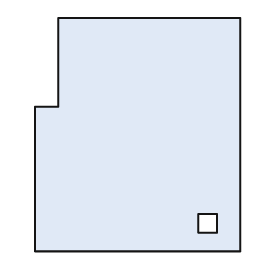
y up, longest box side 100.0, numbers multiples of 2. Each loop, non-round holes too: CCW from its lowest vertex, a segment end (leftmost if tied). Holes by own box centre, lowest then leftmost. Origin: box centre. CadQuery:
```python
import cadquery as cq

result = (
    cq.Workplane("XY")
    .moveTo(-44.0, -50.0)
    .lineTo(44.0, -50.0)
    .lineTo(44.0, 50.0)
    .lineTo(-34.0, 50.0)
    .lineTo(-34.0, 12.0)
    .lineTo(-44.0, 12.0)
    .close()
    .moveTo(26.0, -42.0)
    .lineTo(34.0, -42.0)
    .lineTo(34.0, -34.0)
    .lineTo(26.0, -34.0)
    .close()
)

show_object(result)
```